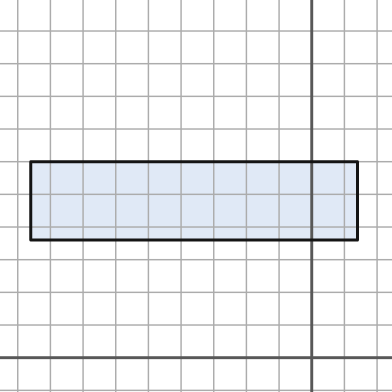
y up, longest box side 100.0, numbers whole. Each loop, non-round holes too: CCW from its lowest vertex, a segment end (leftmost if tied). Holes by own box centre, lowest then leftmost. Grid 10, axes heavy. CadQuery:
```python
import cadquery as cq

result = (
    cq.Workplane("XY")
    .moveTo(-86.0, 36.0)
    .lineTo(14.0, 36.0)
    .lineTo(14.0, 60.0)
    .lineTo(-86.0, 60.0)
    .close()
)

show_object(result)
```